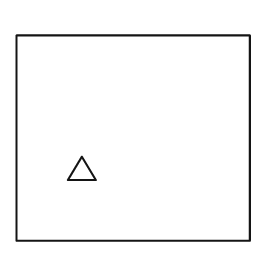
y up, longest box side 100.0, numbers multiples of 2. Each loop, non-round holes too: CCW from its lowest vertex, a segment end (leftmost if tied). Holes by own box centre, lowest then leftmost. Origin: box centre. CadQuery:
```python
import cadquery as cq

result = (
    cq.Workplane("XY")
    .moveTo(-50.0, -44.0)
    .lineTo(50.0, -44.0)
    .lineTo(50.0, 44.0)
    .lineTo(-50.0, 44.0)
    .close()
    .moveTo(-28.0, -18.0)
    .lineTo(-16.0, -18.0)
    .lineTo(-22.0, -8.0)
    .close()
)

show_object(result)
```